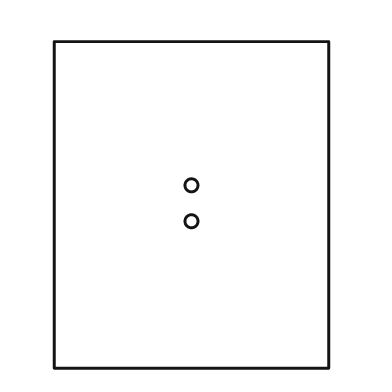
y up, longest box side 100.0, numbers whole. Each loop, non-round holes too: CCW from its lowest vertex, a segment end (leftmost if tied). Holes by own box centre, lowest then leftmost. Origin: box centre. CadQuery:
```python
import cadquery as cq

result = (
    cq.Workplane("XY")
    .moveTo(-42.0, -50.0)
    .lineTo(42.0, -50.0)
    .lineTo(42.0, 50.0)
    .lineTo(-42.0, 50.0)
    .close()
    .moveTo(0.0, -5.0)
    .circle(2.0)
    .moveTo(0.0, 6.0)
    .circle(2.0)
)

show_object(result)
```